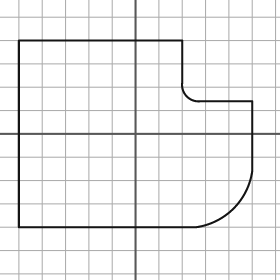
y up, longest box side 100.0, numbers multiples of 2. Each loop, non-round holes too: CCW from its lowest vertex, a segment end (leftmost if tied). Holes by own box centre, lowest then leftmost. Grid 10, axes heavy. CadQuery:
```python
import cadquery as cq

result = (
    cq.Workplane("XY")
    .moveTo(-50.0, -40.0)
    .lineTo(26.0, -40.0)
    .threePointArc((42.0, -32.0), (50.0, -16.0))
    .lineTo(50.0, 14.0)
    .lineTo(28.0, 14.0)
    .threePointArc((22.0, 16.0), (20.0, 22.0))
    .lineTo(20.0, 40.0)
    .lineTo(-50.0, 40.0)
    .close()
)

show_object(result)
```